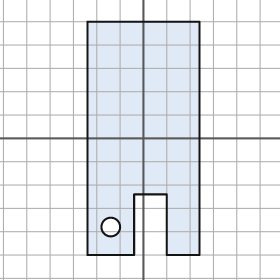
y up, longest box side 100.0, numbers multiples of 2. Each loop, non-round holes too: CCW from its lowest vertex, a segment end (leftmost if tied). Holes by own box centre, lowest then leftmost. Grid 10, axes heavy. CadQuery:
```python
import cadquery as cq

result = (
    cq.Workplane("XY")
    .moveTo(-24.0, -50.0)
    .lineTo(-4.0, -50.0)
    .lineTo(-4.0, -24.0)
    .lineTo(10.0, -24.0)
    .lineTo(10.0, -50.0)
    .lineTo(24.0, -50.0)
    .lineTo(24.0, 50.0)
    .lineTo(-24.0, 50.0)
    .close()
    .moveTo(-14.0, -38.0)
    .circle(4.0)
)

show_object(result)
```